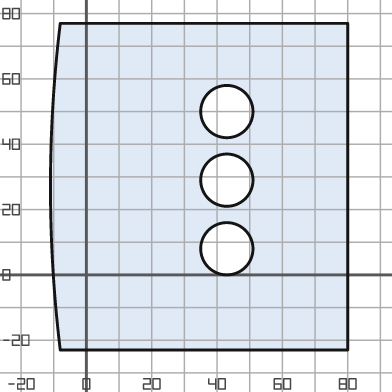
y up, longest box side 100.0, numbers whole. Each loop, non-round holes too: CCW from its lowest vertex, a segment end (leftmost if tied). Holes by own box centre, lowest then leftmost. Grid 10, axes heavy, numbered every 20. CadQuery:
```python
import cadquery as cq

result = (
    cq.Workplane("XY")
    .moveTo(-8.0, -23.0)
    .lineTo(80.0, -23.0)
    .lineTo(80.0, 77.0)
    .lineTo(-8.0, 77.0)
    .threePointArc((-11.0, 27.0), (-8.0, -23.0))
    .close()
    .moveTo(43.0, 8.0)
    .circle(8.0)
    .moveTo(43.0, 29.0)
    .circle(8.0)
    .moveTo(43.0, 50.0)
    .circle(8.0)
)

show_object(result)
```